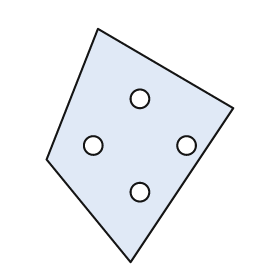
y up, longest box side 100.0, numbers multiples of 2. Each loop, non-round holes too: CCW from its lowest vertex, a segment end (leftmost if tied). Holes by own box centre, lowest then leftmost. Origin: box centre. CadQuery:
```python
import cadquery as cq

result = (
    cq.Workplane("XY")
    .moveTo(-4.0, -50.0)
    .lineTo(40.0, 16.0)
    .lineTo(-18.0, 50.0)
    .lineTo(-40.0, -6.0)
    .close()
    .moveTo(0.0, -20.0)
    .circle(4.0)
    .moveTo(-20.0, 0.0)
    .circle(4.0)
    .moveTo(20.0, 0.0)
    .circle(4.0)
    .moveTo(0.0, 20.0)
    .circle(4.0)
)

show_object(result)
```